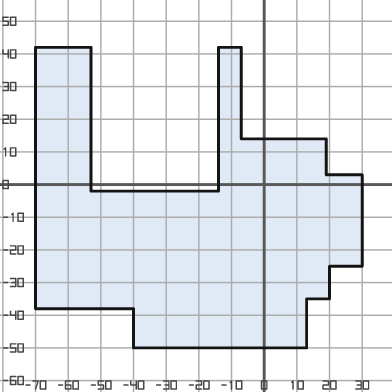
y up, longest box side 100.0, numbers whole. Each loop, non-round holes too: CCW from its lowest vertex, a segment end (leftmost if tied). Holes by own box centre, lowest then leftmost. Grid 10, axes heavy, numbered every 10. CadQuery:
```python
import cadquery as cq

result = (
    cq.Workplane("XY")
    .moveTo(-40.0, -50.0)
    .lineTo(13.0, -50.0)
    .lineTo(13.0, -35.0)
    .lineTo(20.0, -35.0)
    .lineTo(20.0, -25.0)
    .lineTo(30.0, -25.0)
    .lineTo(30.0, 3.0)
    .lineTo(19.0, 3.0)
    .lineTo(19.0, 14.0)
    .lineTo(-7.0, 14.0)
    .lineTo(-7.0, 42.0)
    .lineTo(-14.0, 42.0)
    .lineTo(-14.0, -2.0)
    .lineTo(-53.0, -2.0)
    .lineTo(-53.0, 42.0)
    .lineTo(-70.0, 42.0)
    .lineTo(-70.0, -38.0)
    .lineTo(-40.0, -38.0)
    .close()
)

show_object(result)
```